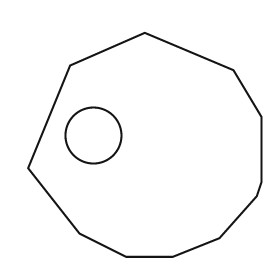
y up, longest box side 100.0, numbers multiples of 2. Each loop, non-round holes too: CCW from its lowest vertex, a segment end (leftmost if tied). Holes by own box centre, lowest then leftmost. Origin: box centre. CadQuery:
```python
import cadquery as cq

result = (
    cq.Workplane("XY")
    .moveTo(-8.0, -48.0)
    .lineTo(12.0, -48.0)
    .lineTo(32.0, -40.0)
    .lineTo(48.0, -22.0)
    .lineTo(50.0, -16.0)
    .lineTo(50.0, 12.0)
    .lineTo(38.0, 32.0)
    .lineTo(0.0, 48.0)
    .lineTo(-32.0, 34.0)
    .lineTo(-50.0, -10.0)
    .lineTo(-28.0, -38.0)
    .close()
    .moveTo(-22.0, 4.0)
    .circle(12.0)
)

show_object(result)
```